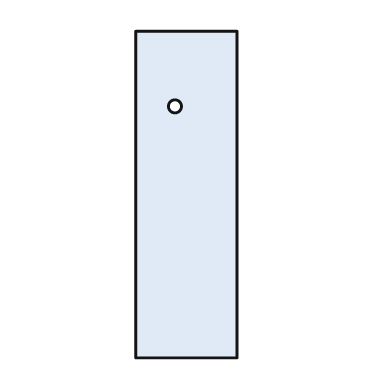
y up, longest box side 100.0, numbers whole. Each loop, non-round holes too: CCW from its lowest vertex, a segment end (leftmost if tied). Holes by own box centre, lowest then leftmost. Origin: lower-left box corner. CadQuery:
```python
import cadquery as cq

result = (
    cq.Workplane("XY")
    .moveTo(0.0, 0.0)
    .lineTo(31.0, 0.0)
    .lineTo(31.0, 100.0)
    .lineTo(0.0, 100.0)
    .close()
    .moveTo(12.0, 77.0)
    .circle(2.0)
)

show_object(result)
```